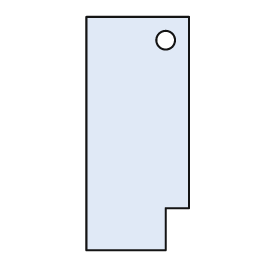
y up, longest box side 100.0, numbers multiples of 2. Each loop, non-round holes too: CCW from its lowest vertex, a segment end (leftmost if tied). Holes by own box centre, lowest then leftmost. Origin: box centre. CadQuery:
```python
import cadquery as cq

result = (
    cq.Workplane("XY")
    .moveTo(-22.0, -50.0)
    .lineTo(12.0, -50.0)
    .lineTo(12.0, -32.0)
    .lineTo(22.0, -32.0)
    .lineTo(22.0, 50.0)
    .lineTo(-22.0, 50.0)
    .close()
    .moveTo(12.0, 40.0)
    .circle(4.0)
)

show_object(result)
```